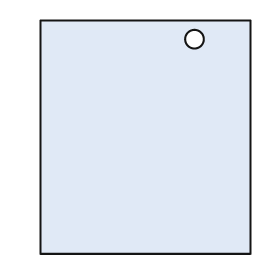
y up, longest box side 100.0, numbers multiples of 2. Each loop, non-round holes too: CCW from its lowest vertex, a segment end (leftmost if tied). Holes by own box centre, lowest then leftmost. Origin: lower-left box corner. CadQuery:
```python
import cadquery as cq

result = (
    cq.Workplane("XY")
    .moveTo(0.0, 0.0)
    .lineTo(90.0, 0.0)
    .lineTo(90.0, 100.0)
    .lineTo(0.0, 100.0)
    .close()
    .moveTo(66.0, 92.0)
    .circle(4.0)
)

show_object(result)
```